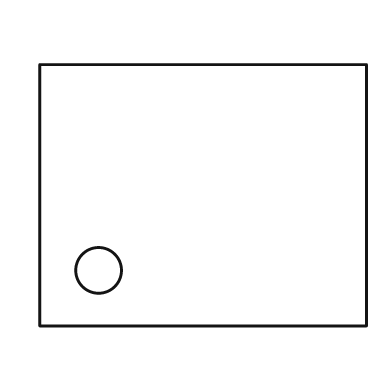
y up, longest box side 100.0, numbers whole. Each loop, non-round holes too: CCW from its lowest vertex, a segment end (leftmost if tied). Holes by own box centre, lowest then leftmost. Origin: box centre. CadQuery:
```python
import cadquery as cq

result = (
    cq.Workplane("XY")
    .moveTo(-50.0, -40.0)
    .lineTo(50.0, -40.0)
    .lineTo(50.0, 40.0)
    .lineTo(-50.0, 40.0)
    .close()
    .moveTo(-32.0, -23.0)
    .circle(7.0)
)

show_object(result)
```